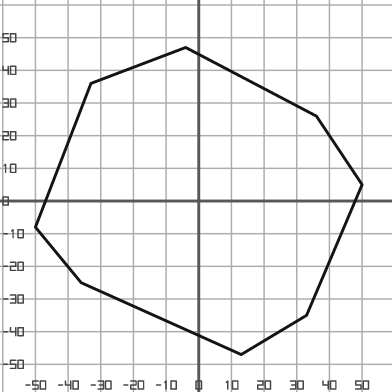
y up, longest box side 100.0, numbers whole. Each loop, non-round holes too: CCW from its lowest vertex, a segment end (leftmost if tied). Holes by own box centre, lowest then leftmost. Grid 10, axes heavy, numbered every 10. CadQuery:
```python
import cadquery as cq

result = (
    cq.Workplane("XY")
    .moveTo(13.0, -47.0)
    .lineTo(33.0, -35.0)
    .lineTo(50.0, 5.0)
    .lineTo(36.0, 26.0)
    .lineTo(-4.0, 47.0)
    .lineTo(-33.0, 36.0)
    .lineTo(-50.0, -8.0)
    .lineTo(-36.0, -25.0)
    .close()
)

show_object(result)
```